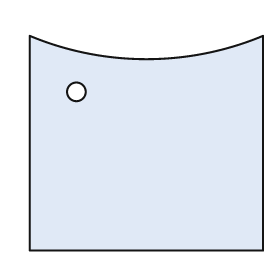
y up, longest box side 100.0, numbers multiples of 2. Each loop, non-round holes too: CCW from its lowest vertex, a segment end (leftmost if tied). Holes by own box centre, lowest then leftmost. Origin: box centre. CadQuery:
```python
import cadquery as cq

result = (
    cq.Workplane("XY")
    .moveTo(-50.0, -46.0)
    .lineTo(50.0, -46.0)
    .lineTo(50.0, 46.0)
    .threePointArc((0.0, 36.0), (-50.0, 46.0))
    .close()
    .moveTo(-30.0, 22.0)
    .circle(4.0)
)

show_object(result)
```